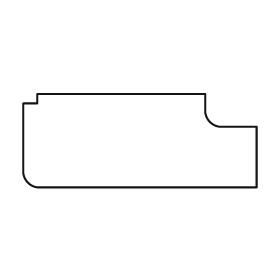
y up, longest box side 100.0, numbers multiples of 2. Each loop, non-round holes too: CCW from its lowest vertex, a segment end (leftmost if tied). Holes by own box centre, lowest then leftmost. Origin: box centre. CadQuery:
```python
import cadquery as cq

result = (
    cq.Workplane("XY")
    .moveTo(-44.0, -20.0)
    .lineTo(50.0, -20.0)
    .lineTo(50.0, 6.0)
    .lineTo(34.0, 6.0)
    .threePointArc((30.0, 8.0), (28.0, 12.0))
    .lineTo(28.0, 20.0)
    .lineTo(-44.0, 20.0)
    .lineTo(-44.0, 16.0)
    .lineTo(-50.0, 16.0)
    .lineTo(-50.0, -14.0)
    .threePointArc((-48.0, -18.0), (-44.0, -20.0))
    .close()
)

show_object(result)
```